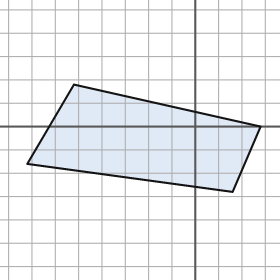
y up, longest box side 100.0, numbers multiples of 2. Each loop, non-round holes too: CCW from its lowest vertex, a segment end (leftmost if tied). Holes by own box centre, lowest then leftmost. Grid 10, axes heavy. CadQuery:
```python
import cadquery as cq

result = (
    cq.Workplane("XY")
    .moveTo(16.0, -28.0)
    .lineTo(28.0, 0.0)
    .lineTo(-52.0, 18.0)
    .lineTo(-72.0, -16.0)
    .close()
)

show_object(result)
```